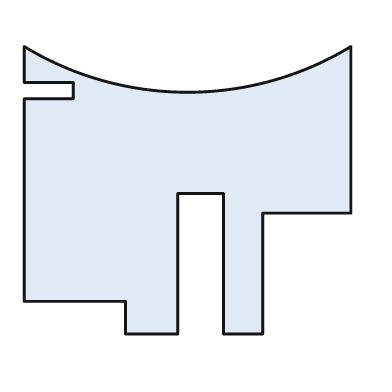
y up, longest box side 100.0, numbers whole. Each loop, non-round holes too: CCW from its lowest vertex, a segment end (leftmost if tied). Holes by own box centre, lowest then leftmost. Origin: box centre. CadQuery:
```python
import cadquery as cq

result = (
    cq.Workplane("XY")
    .moveTo(-19.0, -44.0)
    .lineTo(-3.0, -44.0)
    .lineTo(-3.0, -1.0)
    .lineTo(11.0, -1.0)
    .lineTo(11.0, -44.0)
    .lineTo(23.0, -44.0)
    .lineTo(23.0, -7.0)
    .lineTo(50.0, -7.0)
    .lineTo(50.0, 44.0)
    .threePointArc((0.0, 30.0), (-50.0, 44.0))
    .lineTo(-50.0, 33.0)
    .lineTo(-35.0, 33.0)
    .lineTo(-35.0, 28.0)
    .lineTo(-50.0, 28.0)
    .lineTo(-50.0, -34.0)
    .lineTo(-19.0, -34.0)
    .close()
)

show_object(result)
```